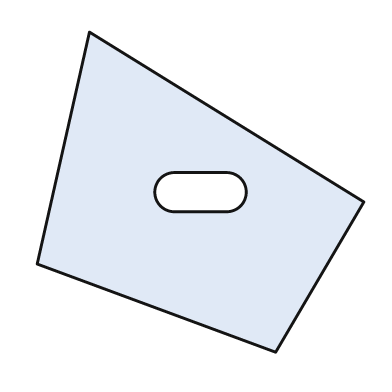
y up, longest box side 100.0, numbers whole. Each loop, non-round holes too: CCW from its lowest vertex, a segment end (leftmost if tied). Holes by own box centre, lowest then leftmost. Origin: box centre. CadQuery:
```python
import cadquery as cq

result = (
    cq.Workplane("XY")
    .moveTo(23.0, -49.0)
    .lineTo(50.0, -3.0)
    .lineTo(-34.0, 49.0)
    .lineTo(-50.0, -22.0)
    .close()
    .moveTo(-8.0, -6.0)
    .lineTo(8.0, -6.0)
    .threePointArc((14.0, 0.0), (8.0, 6.0))
    .lineTo(-8.0, 6.0)
    .threePointArc((-14.0, 0.0), (-8.0, -6.0))
    .close()
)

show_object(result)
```